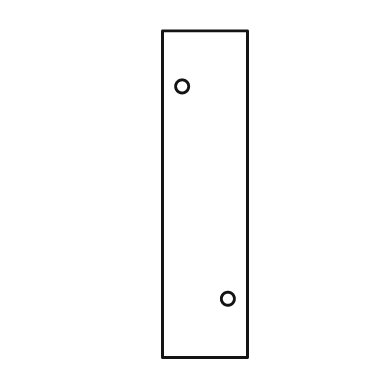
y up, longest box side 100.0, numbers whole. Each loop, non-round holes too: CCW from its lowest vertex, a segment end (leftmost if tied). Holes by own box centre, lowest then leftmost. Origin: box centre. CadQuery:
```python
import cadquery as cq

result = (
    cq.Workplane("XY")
    .moveTo(-13.0, -50.0)
    .lineTo(13.0, -50.0)
    .lineTo(13.0, 50.0)
    .lineTo(-13.0, 50.0)
    .close()
    .moveTo(7.0, -32.0)
    .circle(2.0)
    .moveTo(-7.0, 33.0)
    .circle(2.0)
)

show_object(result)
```